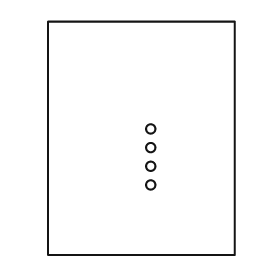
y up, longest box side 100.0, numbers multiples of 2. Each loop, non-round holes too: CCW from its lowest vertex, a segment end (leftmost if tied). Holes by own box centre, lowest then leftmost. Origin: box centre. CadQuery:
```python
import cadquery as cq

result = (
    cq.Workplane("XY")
    .moveTo(-40.0, -50.0)
    .lineTo(40.0, -50.0)
    .lineTo(40.0, 50.0)
    .lineTo(-40.0, 50.0)
    .close()
    .moveTo(4.0, -20.0)
    .circle(2.0)
    .moveTo(4.0, -12.0)
    .circle(2.0)
    .moveTo(4.0, -4.0)
    .circle(2.0)
    .moveTo(4.0, 4.0)
    .circle(2.0)
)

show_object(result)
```